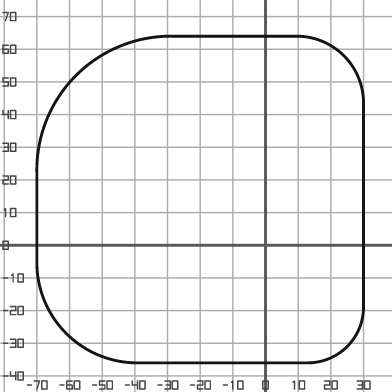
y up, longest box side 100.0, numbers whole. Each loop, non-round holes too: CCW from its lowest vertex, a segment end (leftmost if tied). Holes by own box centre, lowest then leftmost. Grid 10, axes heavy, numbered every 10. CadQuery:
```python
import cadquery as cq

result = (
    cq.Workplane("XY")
    .moveTo(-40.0, -36.0)
    .lineTo(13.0, -36.0)
    .threePointArc((25.0, -31.0), (30.0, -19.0))
    .lineTo(30.0, 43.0)
    .threePointArc((24.0, 58.0), (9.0, 64.0))
    .lineTo(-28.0, 64.0)
    .threePointArc((-58.0, 52.0), (-70.0, 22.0))
    .lineTo(-70.0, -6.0)
    .threePointArc((-61.0, -27.0), (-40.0, -36.0))
    .close()
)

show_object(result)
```